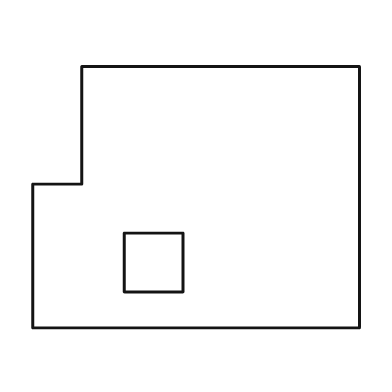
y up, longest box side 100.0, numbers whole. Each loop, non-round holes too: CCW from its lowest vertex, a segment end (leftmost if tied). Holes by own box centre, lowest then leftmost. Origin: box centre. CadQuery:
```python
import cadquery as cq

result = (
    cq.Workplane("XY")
    .moveTo(-50.0, -40.0)
    .lineTo(50.0, -40.0)
    .lineTo(50.0, 40.0)
    .lineTo(-35.0, 40.0)
    .lineTo(-35.0, 4.0)
    .lineTo(-50.0, 4.0)
    .close()
    .moveTo(-22.0, -29.0)
    .lineTo(-4.0, -29.0)
    .lineTo(-4.0, -11.0)
    .lineTo(-22.0, -11.0)
    .close()
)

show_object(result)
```